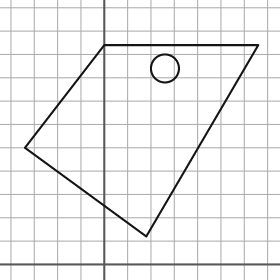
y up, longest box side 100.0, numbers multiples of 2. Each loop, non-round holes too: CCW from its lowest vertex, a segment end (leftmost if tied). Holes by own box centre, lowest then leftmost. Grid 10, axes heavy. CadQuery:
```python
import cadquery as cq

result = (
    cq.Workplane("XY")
    .moveTo(18.0, 12.0)
    .lineTo(66.0, 94.0)
    .lineTo(0.0, 94.0)
    .lineTo(-34.0, 50.0)
    .close()
    .moveTo(26.0, 84.0)
    .circle(6.0)
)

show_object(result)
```